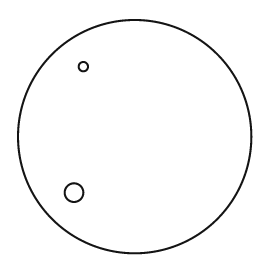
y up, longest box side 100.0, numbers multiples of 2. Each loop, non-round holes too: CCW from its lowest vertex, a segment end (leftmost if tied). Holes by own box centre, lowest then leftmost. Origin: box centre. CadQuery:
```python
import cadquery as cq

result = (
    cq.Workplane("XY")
    .moveTo(0.0, 0.0)
    .circle(50.0)
    .moveTo(-26.0, -24.0)
    .circle(4.0)
    .moveTo(-22.0, 30.0)
    .circle(2.0)
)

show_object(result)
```